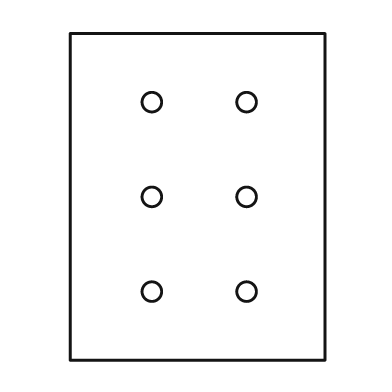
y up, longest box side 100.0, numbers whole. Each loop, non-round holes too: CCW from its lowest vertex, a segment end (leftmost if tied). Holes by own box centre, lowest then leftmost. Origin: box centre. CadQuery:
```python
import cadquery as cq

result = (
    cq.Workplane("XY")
    .moveTo(-39.0, -50.0)
    .lineTo(39.0, -50.0)
    .lineTo(39.0, 50.0)
    .lineTo(-39.0, 50.0)
    .close()
    .moveTo(-14.0, -29.0)
    .circle(3.0)
    .moveTo(15.0, -29.0)
    .circle(3.0)
    .moveTo(-14.0, 0.0)
    .circle(3.0)
    .moveTo(15.0, 0.0)
    .circle(3.0)
    .moveTo(-14.0, 29.0)
    .circle(3.0)
    .moveTo(15.0, 29.0)
    .circle(3.0)
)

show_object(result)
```